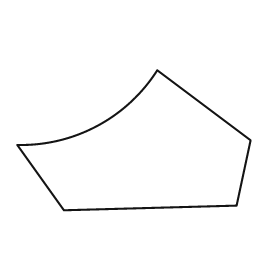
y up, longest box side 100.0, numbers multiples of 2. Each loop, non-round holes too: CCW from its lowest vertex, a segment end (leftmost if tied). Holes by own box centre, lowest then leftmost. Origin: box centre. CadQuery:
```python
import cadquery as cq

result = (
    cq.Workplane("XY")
    .moveTo(-30.0, -30.0)
    .lineTo(44.0, -28.0)
    .lineTo(50.0, 0.0)
    .lineTo(10.0, 30.0)
    .threePointArc((-16.0, 6.0), (-50.0, -2.0))
    .close()
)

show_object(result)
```